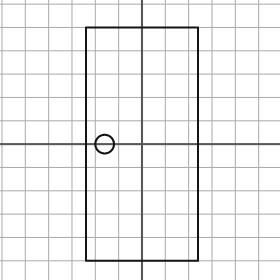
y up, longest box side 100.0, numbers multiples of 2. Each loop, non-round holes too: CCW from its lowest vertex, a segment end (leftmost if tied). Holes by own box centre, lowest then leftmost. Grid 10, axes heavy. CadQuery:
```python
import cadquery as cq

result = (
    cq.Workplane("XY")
    .moveTo(-24.0, -50.0)
    .lineTo(24.0, -50.0)
    .lineTo(24.0, 50.0)
    .lineTo(-24.0, 50.0)
    .close()
    .moveTo(-16.0, 0.0)
    .circle(4.0)
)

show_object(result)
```